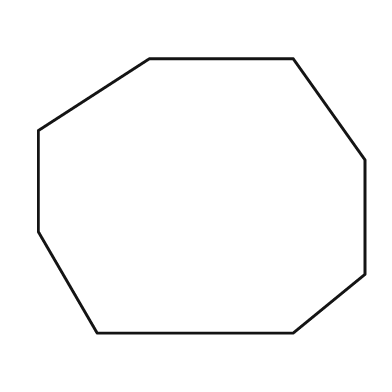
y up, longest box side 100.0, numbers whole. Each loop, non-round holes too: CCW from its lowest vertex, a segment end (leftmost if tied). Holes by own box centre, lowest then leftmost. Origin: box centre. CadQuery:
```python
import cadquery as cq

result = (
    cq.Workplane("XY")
    .moveTo(-32.0, -42.0)
    .lineTo(28.0, -42.0)
    .lineTo(50.0, -24.0)
    .lineTo(50.0, 11.0)
    .lineTo(28.0, 42.0)
    .lineTo(-16.0, 42.0)
    .lineTo(-50.0, 20.0)
    .lineTo(-50.0, -11.0)
    .close()
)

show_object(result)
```